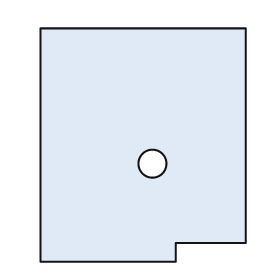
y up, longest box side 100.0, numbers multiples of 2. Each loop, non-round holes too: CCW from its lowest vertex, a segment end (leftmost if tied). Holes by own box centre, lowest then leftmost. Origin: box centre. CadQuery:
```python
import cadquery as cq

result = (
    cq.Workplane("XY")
    .moveTo(-44.0, -50.0)
    .lineTo(14.0, -50.0)
    .lineTo(14.0, -42.0)
    .lineTo(44.0, -42.0)
    .lineTo(44.0, 50.0)
    .lineTo(-44.0, 50.0)
    .close()
    .moveTo(4.0, -8.0)
    .circle(6.0)
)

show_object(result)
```